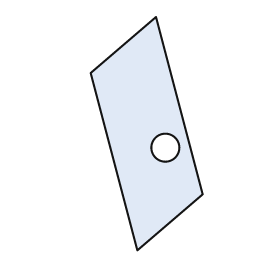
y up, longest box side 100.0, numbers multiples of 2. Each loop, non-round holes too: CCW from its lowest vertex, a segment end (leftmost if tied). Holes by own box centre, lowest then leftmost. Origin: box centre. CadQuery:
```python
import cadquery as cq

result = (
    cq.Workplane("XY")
    .moveTo(-4.0, -50.0)
    .lineTo(24.0, -26.0)
    .lineTo(4.0, 50.0)
    .lineTo(-24.0, 26.0)
    .close()
    .moveTo(8.0, -6.0)
    .circle(6.0)
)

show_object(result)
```